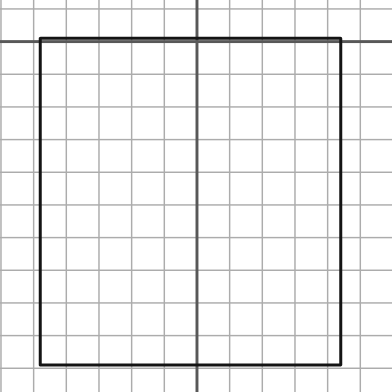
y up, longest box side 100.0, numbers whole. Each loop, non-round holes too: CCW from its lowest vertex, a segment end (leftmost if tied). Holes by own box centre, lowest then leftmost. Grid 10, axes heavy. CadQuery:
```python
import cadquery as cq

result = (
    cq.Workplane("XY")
    .moveTo(-48.0, -99.0)
    .lineTo(44.0, -99.0)
    .lineTo(44.0, 1.0)
    .lineTo(-48.0, 1.0)
    .close()
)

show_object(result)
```